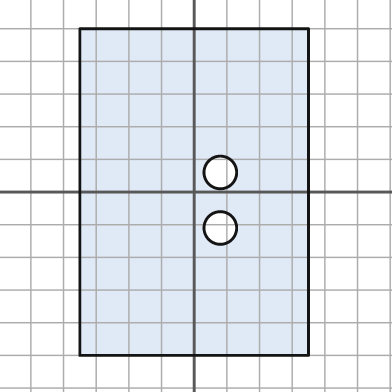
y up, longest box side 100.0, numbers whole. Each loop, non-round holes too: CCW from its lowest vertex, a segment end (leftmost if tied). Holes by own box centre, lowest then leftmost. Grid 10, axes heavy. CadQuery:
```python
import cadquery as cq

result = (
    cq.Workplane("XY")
    .moveTo(-35.0, -50.0)
    .lineTo(35.0, -50.0)
    .lineTo(35.0, 50.0)
    .lineTo(-35.0, 50.0)
    .close()
    .moveTo(8.0, -11.0)
    .circle(5.0)
    .moveTo(8.0, 6.0)
    .circle(5.0)
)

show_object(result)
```